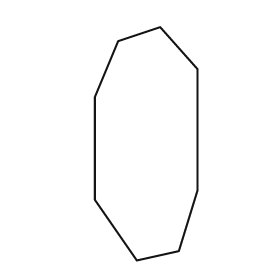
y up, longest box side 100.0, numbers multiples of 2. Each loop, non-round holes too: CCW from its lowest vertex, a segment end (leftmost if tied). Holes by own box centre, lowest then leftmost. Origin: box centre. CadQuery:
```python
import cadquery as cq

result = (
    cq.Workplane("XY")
    .moveTo(-4.0, -50.0)
    .lineTo(14.0, -46.0)
    .lineTo(22.0, -20.0)
    .lineTo(22.0, 32.0)
    .lineTo(6.0, 50.0)
    .lineTo(-12.0, 44.0)
    .lineTo(-22.0, 20.0)
    .lineTo(-22.0, -24.0)
    .close()
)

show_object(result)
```